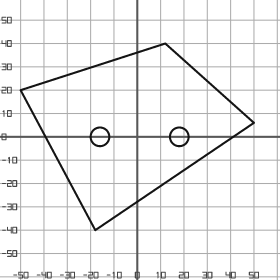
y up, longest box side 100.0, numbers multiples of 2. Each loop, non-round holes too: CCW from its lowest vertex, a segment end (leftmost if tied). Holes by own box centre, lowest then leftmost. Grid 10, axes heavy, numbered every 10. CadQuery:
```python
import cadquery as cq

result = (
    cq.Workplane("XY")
    .moveTo(-18.0, -40.0)
    .lineTo(50.0, 6.0)
    .lineTo(12.0, 40.0)
    .lineTo(-50.0, 20.0)
    .close()
    .moveTo(-16.0, 0.0)
    .circle(4.0)
    .moveTo(18.0, 0.0)
    .circle(4.0)
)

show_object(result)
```